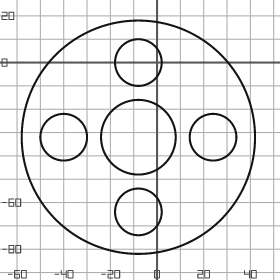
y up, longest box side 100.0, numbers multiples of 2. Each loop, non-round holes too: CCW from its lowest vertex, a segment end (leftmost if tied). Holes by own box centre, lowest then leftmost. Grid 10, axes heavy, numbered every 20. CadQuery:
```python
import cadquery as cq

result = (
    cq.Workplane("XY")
    .moveTo(-8.0, -32.0)
    .circle(50.0)
    .moveTo(-8.0, -64.0)
    .circle(10.0)
    .moveTo(-40.0, -32.0)
    .circle(10.0)
    .moveTo(-8.0, -32.0)
    .circle(16.0)
    .moveTo(24.0, -32.0)
    .circle(10.0)
    .moveTo(-8.0, 0.0)
    .circle(10.0)
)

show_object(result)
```